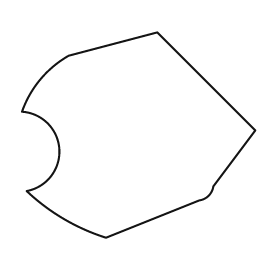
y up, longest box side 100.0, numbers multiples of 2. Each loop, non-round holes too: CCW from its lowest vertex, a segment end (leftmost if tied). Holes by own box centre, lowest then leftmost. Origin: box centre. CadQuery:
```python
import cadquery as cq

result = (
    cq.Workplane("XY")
    .moveTo(-14.0, -44.0)
    .lineTo(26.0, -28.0)
    .threePointArc((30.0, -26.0), (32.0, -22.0))
    .lineTo(50.0, 2.0)
    .lineTo(8.0, 44.0)
    .lineTo(-30.0, 34.0)
    .threePointArc((-42.0, 24.0), (-50.0, 10.0))
    .threePointArc((-34.0, -6.0), (-48.0, -24.0))
    .threePointArc((-32.0, -36.0), (-14.0, -44.0))
    .close()
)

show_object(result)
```